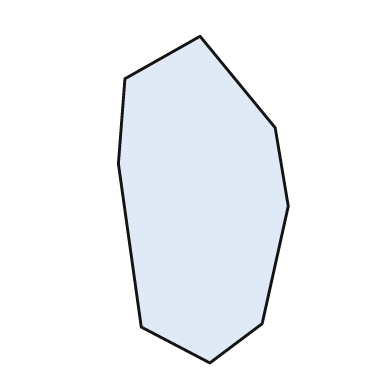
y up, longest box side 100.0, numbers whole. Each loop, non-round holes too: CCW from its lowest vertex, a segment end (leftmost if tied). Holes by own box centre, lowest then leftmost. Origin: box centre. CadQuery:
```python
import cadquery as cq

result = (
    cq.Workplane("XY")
    .moveTo(2.0, -50.0)
    .lineTo(18.0, -38.0)
    .lineTo(26.0, -2.0)
    .lineTo(22.0, 22.0)
    .lineTo(-1.0, 50.0)
    .lineTo(-24.0, 37.0)
    .lineTo(-26.0, 11.0)
    .lineTo(-19.0, -39.0)
    .close()
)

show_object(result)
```